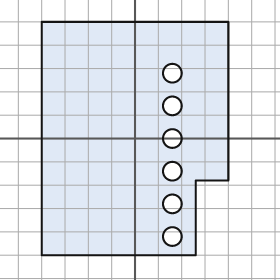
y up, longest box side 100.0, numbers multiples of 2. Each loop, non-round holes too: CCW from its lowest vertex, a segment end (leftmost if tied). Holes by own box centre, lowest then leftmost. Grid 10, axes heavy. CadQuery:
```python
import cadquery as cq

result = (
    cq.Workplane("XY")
    .moveTo(-40.0, -50.0)
    .lineTo(26.0, -50.0)
    .lineTo(26.0, -18.0)
    .lineTo(40.0, -18.0)
    .lineTo(40.0, 50.0)
    .lineTo(-40.0, 50.0)
    .close()
    .moveTo(16.0, -42.0)
    .circle(4.0)
    .moveTo(16.0, -28.0)
    .circle(4.0)
    .moveTo(16.0, -14.0)
    .circle(4.0)
    .moveTo(16.0, 0.0)
    .circle(4.0)
    .moveTo(16.0, 14.0)
    .circle(4.0)
    .moveTo(16.0, 28.0)
    .circle(4.0)
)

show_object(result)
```